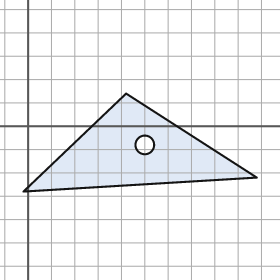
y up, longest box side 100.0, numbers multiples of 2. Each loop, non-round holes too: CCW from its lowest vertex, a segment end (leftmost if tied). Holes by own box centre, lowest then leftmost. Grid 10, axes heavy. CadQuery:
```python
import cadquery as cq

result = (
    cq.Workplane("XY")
    .moveTo(-2.0, -28.0)
    .lineTo(98.0, -22.0)
    .lineTo(42.0, 14.0)
    .close()
    .moveTo(50.0, -8.0)
    .circle(4.0)
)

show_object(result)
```